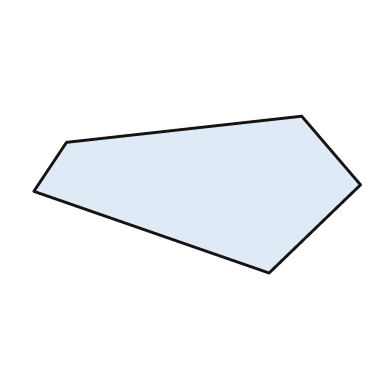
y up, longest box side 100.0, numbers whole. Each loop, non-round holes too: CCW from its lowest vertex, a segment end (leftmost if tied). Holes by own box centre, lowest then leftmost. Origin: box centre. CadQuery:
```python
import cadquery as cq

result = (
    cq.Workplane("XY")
    .moveTo(22.0, -24.0)
    .lineTo(50.0, 3.0)
    .lineTo(32.0, 24.0)
    .lineTo(-40.0, 16.0)
    .lineTo(-50.0, 1.0)
    .close()
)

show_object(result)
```